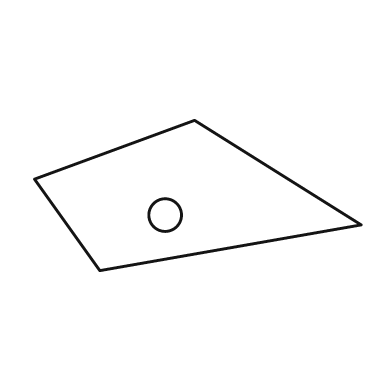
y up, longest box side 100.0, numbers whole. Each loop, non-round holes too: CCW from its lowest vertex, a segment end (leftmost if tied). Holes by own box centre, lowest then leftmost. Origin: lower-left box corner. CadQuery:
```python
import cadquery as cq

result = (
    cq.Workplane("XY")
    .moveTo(20.0, 0.0)
    .lineTo(100.0, 14.0)
    .lineTo(49.0, 46.0)
    .lineTo(0.0, 28.0)
    .close()
    .moveTo(40.0, 17.0)
    .circle(5.0)
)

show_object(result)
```